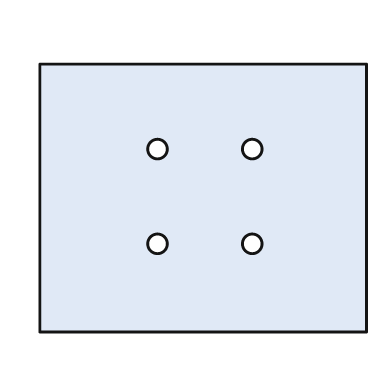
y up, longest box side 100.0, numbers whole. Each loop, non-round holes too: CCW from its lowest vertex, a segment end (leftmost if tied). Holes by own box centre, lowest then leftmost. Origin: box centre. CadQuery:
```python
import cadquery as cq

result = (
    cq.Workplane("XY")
    .moveTo(-50.0, -41.0)
    .lineTo(50.0, -41.0)
    .lineTo(50.0, 41.0)
    .lineTo(-50.0, 41.0)
    .close()
    .moveTo(-14.0, -14.0)
    .circle(3.0)
    .moveTo(15.0, -14.0)
    .circle(3.0)
    .moveTo(-14.0, 15.0)
    .circle(3.0)
    .moveTo(15.0, 15.0)
    .circle(3.0)
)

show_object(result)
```